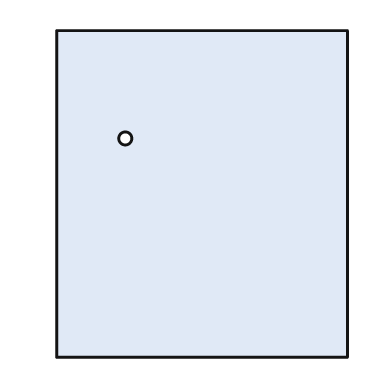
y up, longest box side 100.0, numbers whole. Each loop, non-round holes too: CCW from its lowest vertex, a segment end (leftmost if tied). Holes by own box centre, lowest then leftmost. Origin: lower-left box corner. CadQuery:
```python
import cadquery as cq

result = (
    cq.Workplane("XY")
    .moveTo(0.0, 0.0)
    .lineTo(89.0, 0.0)
    .lineTo(89.0, 100.0)
    .lineTo(0.0, 100.0)
    .close()
    .moveTo(21.0, 67.0)
    .circle(2.0)
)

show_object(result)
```